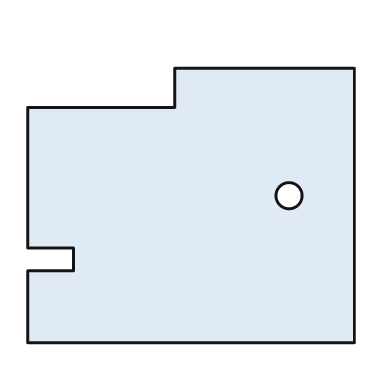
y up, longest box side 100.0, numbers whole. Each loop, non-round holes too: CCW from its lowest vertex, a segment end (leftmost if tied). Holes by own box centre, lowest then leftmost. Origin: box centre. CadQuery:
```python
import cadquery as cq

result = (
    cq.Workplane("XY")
    .moveTo(-50.0, -42.0)
    .lineTo(50.0, -42.0)
    .lineTo(50.0, 42.0)
    .lineTo(-5.0, 42.0)
    .lineTo(-5.0, 30.0)
    .lineTo(-50.0, 30.0)
    .lineTo(-50.0, -13.0)
    .lineTo(-36.0, -13.0)
    .lineTo(-36.0, -20.0)
    .lineTo(-50.0, -20.0)
    .close()
    .moveTo(30.0, 3.0)
    .circle(4.0)
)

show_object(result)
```